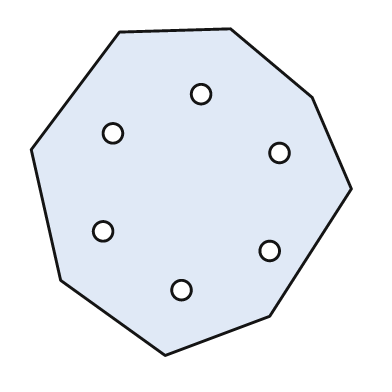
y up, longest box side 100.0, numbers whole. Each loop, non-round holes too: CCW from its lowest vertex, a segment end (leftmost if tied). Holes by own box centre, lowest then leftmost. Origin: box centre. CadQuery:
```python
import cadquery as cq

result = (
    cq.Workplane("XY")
    .moveTo(-8.0, -50.0)
    .lineTo(24.0, -38.0)
    .lineTo(49.0, 1.0)
    .lineTo(37.0, 29.0)
    .lineTo(12.0, 50.0)
    .lineTo(-22.0, 49.0)
    .lineTo(-49.0, 13.0)
    .lineTo(-40.0, -27.0)
    .close()
    .moveTo(-3.0, -30.0)
    .circle(3.0)
    .moveTo(24.0, -18.0)
    .circle(3.0)
    .moveTo(-27.0, -12.0)
    .circle(3.0)
    .moveTo(27.0, 12.0)
    .circle(3.0)
    .moveTo(-24.0, 18.0)
    .circle(3.0)
    .moveTo(3.0, 30.0)
    .circle(3.0)
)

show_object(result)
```